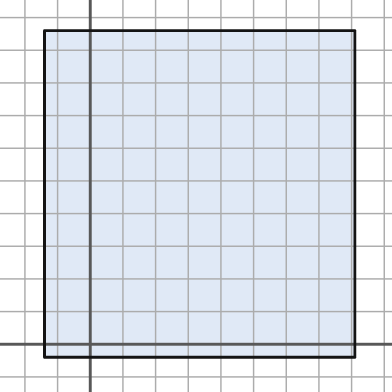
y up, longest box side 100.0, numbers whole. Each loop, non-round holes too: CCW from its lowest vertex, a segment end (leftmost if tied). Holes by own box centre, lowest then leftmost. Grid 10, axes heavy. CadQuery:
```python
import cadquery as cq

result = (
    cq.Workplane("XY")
    .moveTo(-14.0, -4.0)
    .lineTo(81.0, -4.0)
    .lineTo(81.0, 96.0)
    .lineTo(-14.0, 96.0)
    .close()
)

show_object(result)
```